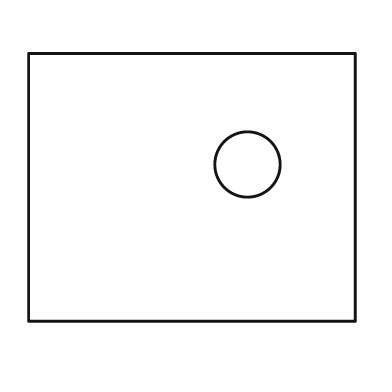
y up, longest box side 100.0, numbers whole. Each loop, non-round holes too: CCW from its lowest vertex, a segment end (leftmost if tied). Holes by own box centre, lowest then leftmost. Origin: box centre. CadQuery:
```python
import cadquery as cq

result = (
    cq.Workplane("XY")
    .moveTo(-50.0, -41.0)
    .lineTo(50.0, -41.0)
    .lineTo(50.0, 41.0)
    .lineTo(-50.0, 41.0)
    .close()
    .moveTo(17.0, 7.0)
    .circle(10.0)
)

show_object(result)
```